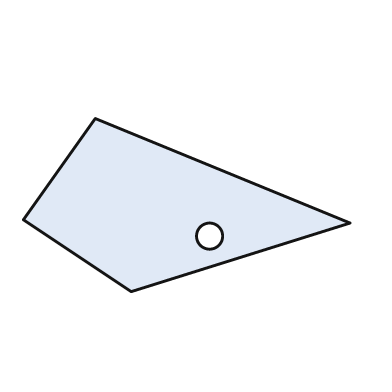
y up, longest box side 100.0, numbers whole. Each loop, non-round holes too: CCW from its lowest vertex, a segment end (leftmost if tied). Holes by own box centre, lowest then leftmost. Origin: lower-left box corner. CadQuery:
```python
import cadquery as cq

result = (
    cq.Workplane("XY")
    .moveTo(33.0, 0.0)
    .lineTo(100.0, 21.0)
    .lineTo(22.0, 53.0)
    .lineTo(0.0, 22.0)
    .close()
    .moveTo(57.0, 17.0)
    .circle(4.0)
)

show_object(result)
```